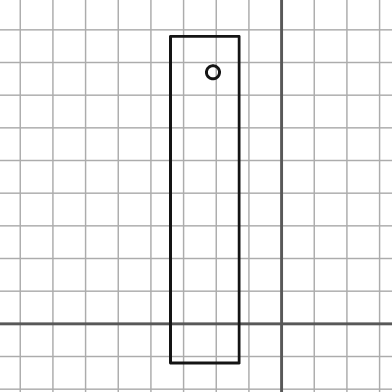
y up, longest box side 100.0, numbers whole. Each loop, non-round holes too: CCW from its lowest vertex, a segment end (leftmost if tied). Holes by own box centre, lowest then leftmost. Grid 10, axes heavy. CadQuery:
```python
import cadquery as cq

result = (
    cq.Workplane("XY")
    .moveTo(-34.0, -12.0)
    .lineTo(-13.0, -12.0)
    .lineTo(-13.0, 88.0)
    .lineTo(-34.0, 88.0)
    .close()
    .moveTo(-21.0, 77.0)
    .circle(2.0)
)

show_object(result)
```